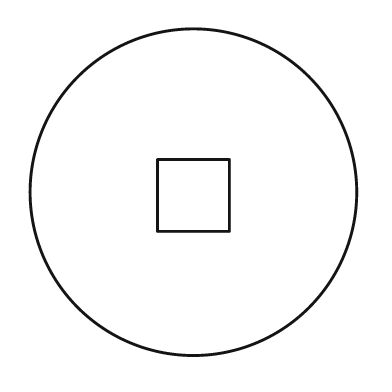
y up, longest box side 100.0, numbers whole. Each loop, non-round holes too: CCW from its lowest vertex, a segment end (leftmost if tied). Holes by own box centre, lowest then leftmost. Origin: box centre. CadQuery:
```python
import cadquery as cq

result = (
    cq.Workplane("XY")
    .moveTo(0.0, 0.0)
    .circle(50.0)
    .moveTo(-11.0, -12.0)
    .lineTo(11.0, -12.0)
    .lineTo(11.0, 10.0)
    .lineTo(-11.0, 10.0)
    .close()
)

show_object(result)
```